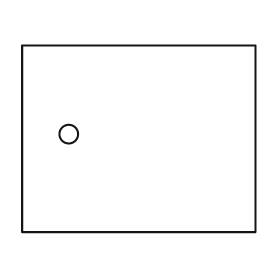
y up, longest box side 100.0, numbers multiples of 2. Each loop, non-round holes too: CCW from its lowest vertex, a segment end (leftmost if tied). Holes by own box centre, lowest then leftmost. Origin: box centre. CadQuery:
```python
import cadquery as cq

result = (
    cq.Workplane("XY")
    .moveTo(-50.0, -40.0)
    .lineTo(50.0, -40.0)
    .lineTo(50.0, 40.0)
    .lineTo(-50.0, 40.0)
    .close()
    .moveTo(-30.0, 2.0)
    .circle(4.0)
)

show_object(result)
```